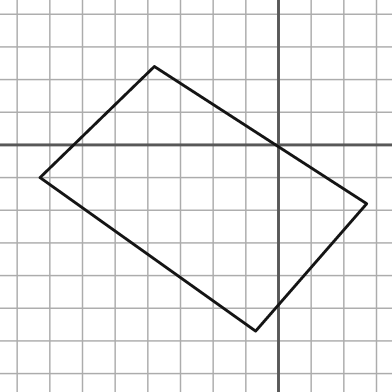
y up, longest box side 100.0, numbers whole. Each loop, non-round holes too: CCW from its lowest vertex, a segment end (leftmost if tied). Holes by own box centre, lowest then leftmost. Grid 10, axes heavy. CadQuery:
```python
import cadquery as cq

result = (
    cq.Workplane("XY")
    .moveTo(-7.0, -57.0)
    .lineTo(27.0, -18.0)
    .lineTo(-38.0, 24.0)
    .lineTo(-73.0, -10.0)
    .close()
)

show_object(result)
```